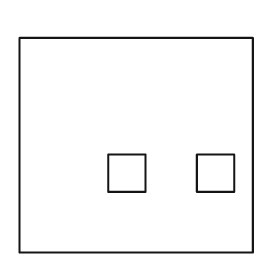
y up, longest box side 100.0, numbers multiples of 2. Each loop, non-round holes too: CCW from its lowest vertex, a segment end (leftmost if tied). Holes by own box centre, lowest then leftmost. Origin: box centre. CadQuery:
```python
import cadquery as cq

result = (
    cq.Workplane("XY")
    .moveTo(-50.0, -46.0)
    .lineTo(50.0, -46.0)
    .lineTo(50.0, 46.0)
    .lineTo(-50.0, 46.0)
    .close()
    .moveTo(-12.0, -20.0)
    .lineTo(4.0, -20.0)
    .lineTo(4.0, -4.0)
    .lineTo(-12.0, -4.0)
    .close()
    .moveTo(26.0, -20.0)
    .lineTo(42.0, -20.0)
    .lineTo(42.0, -4.0)
    .lineTo(26.0, -4.0)
    .close()
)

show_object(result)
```